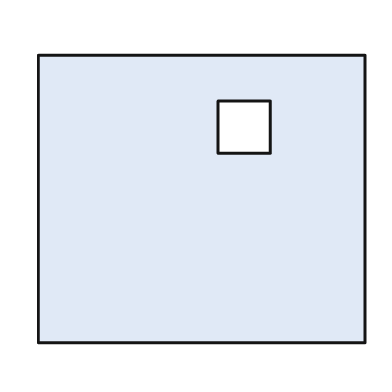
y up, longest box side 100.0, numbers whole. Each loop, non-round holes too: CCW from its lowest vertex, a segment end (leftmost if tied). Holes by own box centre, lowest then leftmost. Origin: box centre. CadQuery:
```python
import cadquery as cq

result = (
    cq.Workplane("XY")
    .moveTo(-50.0, -44.0)
    .lineTo(50.0, -44.0)
    .lineTo(50.0, 44.0)
    .lineTo(-50.0, 44.0)
    .close()
    .moveTo(5.0, 14.0)
    .lineTo(21.0, 14.0)
    .lineTo(21.0, 30.0)
    .lineTo(5.0, 30.0)
    .close()
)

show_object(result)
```